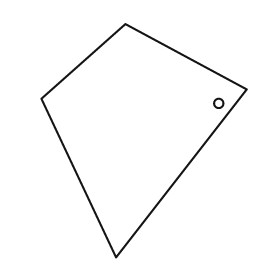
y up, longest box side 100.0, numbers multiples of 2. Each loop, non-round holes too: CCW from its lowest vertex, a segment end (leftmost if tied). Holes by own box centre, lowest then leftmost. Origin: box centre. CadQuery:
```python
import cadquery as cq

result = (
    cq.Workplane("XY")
    .moveTo(-12.0, -50.0)
    .lineTo(44.0, 22.0)
    .lineTo(-8.0, 50.0)
    .lineTo(-44.0, 18.0)
    .close()
    .moveTo(32.0, 16.0)
    .circle(2.0)
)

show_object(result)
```